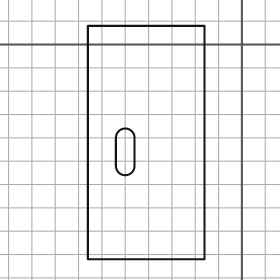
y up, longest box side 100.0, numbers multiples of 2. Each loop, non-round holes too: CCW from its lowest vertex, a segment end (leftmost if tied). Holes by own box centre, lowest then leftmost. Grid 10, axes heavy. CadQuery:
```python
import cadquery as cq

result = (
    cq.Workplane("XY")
    .moveTo(-66.0, -92.0)
    .lineTo(-16.0, -92.0)
    .lineTo(-16.0, 8.0)
    .lineTo(-66.0, 8.0)
    .close()
    .moveTo(-54.0, -52.0)
    .threePointArc((-50.0, -56.0), (-46.0, -52.0))
    .lineTo(-46.0, -40.0)
    .threePointArc((-50.0, -36.0), (-54.0, -40.0))
    .close()
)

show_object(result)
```